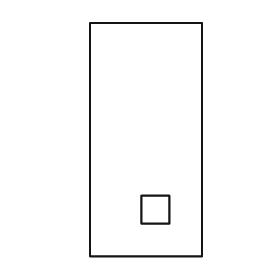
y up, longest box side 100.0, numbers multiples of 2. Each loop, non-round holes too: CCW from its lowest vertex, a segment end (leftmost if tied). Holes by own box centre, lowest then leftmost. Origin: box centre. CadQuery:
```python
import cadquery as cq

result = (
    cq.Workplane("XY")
    .moveTo(-24.0, -50.0)
    .lineTo(24.0, -50.0)
    .lineTo(24.0, 50.0)
    .lineTo(-24.0, 50.0)
    .close()
    .moveTo(-2.0, -36.0)
    .lineTo(10.0, -36.0)
    .lineTo(10.0, -24.0)
    .lineTo(-2.0, -24.0)
    .close()
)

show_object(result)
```